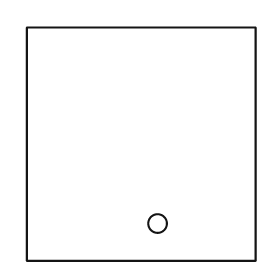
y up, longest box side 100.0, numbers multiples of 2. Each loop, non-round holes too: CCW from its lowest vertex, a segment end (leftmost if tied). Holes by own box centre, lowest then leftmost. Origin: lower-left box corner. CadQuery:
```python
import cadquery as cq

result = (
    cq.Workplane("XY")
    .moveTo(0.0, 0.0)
    .lineTo(98.0, 0.0)
    .lineTo(98.0, 100.0)
    .lineTo(0.0, 100.0)
    .close()
    .moveTo(56.0, 16.0)
    .circle(4.0)
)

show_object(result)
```